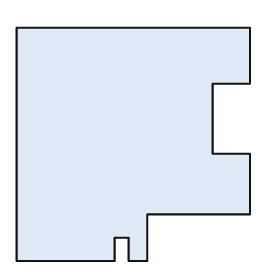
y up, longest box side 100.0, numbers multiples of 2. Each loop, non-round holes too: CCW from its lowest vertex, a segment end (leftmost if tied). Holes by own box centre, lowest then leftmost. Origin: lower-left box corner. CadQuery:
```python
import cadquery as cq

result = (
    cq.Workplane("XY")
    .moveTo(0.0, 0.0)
    .lineTo(42.0, 0.0)
    .lineTo(42.0, 10.0)
    .lineTo(48.0, 10.0)
    .lineTo(48.0, 0.0)
    .lineTo(56.0, 0.0)
    .lineTo(56.0, 20.0)
    .lineTo(100.0, 20.0)
    .lineTo(100.0, 46.0)
    .lineTo(84.0, 46.0)
    .lineTo(84.0, 76.0)
    .lineTo(100.0, 76.0)
    .lineTo(100.0, 100.0)
    .lineTo(0.0, 100.0)
    .close()
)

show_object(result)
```